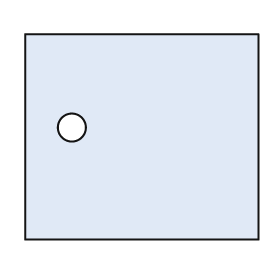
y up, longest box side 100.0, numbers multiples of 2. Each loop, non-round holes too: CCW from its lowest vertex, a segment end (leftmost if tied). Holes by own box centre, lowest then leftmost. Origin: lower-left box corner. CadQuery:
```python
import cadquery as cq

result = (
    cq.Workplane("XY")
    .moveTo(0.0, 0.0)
    .lineTo(100.0, 0.0)
    .lineTo(100.0, 88.0)
    .lineTo(0.0, 88.0)
    .close()
    .moveTo(20.0, 48.0)
    .circle(6.0)
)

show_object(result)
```